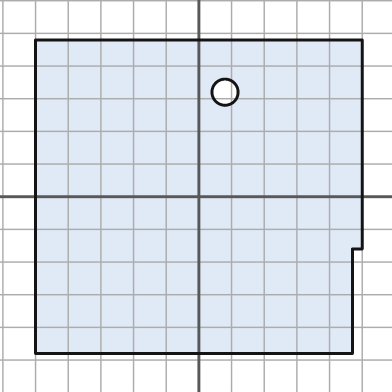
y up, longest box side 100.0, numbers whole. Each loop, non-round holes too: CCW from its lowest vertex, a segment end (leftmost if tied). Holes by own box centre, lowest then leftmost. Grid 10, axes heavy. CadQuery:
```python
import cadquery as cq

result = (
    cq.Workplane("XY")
    .moveTo(-50.0, -48.0)
    .lineTo(47.0, -48.0)
    .lineTo(47.0, -16.0)
    .lineTo(50.0, -16.0)
    .lineTo(50.0, 48.0)
    .lineTo(-50.0, 48.0)
    .close()
    .moveTo(8.0, 32.0)
    .circle(4.0)
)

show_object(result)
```